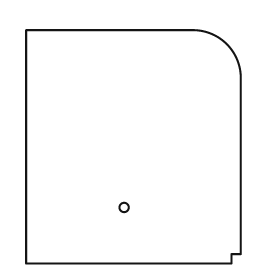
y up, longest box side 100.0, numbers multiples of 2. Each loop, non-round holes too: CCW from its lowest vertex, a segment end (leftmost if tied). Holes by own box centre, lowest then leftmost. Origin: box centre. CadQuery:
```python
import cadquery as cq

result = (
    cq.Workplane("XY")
    .moveTo(-46.0, -50.0)
    .lineTo(42.0, -50.0)
    .lineTo(42.0, -46.0)
    .lineTo(46.0, -46.0)
    .lineTo(46.0, 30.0)
    .threePointArc((40.0, 44.0), (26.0, 50.0))
    .lineTo(-46.0, 50.0)
    .close()
    .moveTo(-4.0, -26.0)
    .circle(2.0)
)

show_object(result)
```